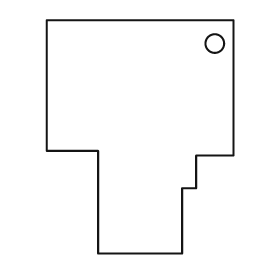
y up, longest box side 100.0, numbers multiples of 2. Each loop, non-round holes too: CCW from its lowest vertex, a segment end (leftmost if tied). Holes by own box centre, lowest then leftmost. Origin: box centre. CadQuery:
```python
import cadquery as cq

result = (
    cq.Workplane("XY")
    .moveTo(-18.0, -50.0)
    .lineTo(18.0, -50.0)
    .lineTo(18.0, -22.0)
    .lineTo(24.0, -22.0)
    .lineTo(24.0, -8.0)
    .lineTo(40.0, -8.0)
    .lineTo(40.0, 50.0)
    .lineTo(-40.0, 50.0)
    .lineTo(-40.0, -6.0)
    .lineTo(-18.0, -6.0)
    .close()
    .moveTo(32.0, 40.0)
    .circle(4.0)
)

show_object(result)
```